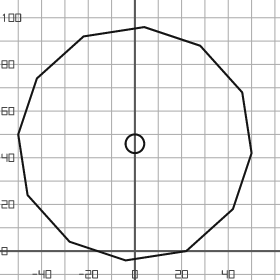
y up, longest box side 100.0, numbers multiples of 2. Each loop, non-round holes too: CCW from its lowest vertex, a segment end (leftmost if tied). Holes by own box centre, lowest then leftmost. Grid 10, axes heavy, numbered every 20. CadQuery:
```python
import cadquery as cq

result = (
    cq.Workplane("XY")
    .moveTo(-4.0, -4.0)
    .lineTo(22.0, 0.0)
    .lineTo(42.0, 18.0)
    .lineTo(50.0, 42.0)
    .lineTo(46.0, 68.0)
    .lineTo(28.0, 88.0)
    .lineTo(4.0, 96.0)
    .lineTo(-22.0, 92.0)
    .lineTo(-42.0, 74.0)
    .lineTo(-50.0, 50.0)
    .lineTo(-46.0, 24.0)
    .lineTo(-28.0, 4.0)
    .close()
    .moveTo(0.0, 46.0)
    .circle(4.0)
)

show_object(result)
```